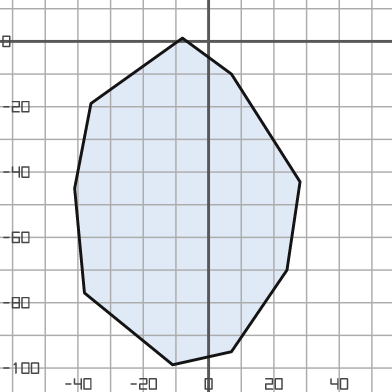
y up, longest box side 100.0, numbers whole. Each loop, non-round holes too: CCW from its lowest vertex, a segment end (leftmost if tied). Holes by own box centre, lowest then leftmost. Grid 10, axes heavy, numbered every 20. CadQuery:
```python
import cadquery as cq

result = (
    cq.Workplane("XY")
    .moveTo(-11.0, -99.0)
    .lineTo(7.0, -95.0)
    .lineTo(24.0, -70.0)
    .lineTo(28.0, -43.0)
    .lineTo(7.0, -10.0)
    .lineTo(-8.0, 1.0)
    .lineTo(-36.0, -19.0)
    .lineTo(-41.0, -45.0)
    .lineTo(-38.0, -77.0)
    .close()
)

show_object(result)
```